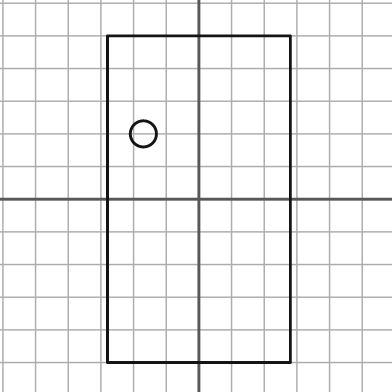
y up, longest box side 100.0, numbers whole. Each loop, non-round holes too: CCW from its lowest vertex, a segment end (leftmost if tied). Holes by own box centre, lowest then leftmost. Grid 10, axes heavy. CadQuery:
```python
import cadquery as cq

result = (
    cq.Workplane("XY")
    .moveTo(-28.0, -50.0)
    .lineTo(28.0, -50.0)
    .lineTo(28.0, 50.0)
    .lineTo(-28.0, 50.0)
    .close()
    .moveTo(-17.0, 20.0)
    .circle(4.0)
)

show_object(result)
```